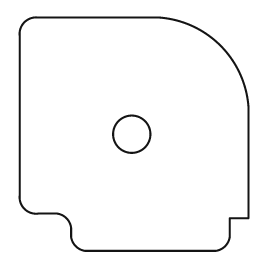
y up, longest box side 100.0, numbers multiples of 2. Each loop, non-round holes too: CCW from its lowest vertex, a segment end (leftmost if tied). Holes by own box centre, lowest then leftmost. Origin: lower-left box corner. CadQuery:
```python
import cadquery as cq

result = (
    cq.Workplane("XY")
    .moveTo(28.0, 0.0)
    .lineTo(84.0, 0.0)
    .threePointArc((88.0, 2.0), (90.0, 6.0))
    .lineTo(90.0, 14.0)
    .lineTo(98.0, 14.0)
    .lineTo(98.0, 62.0)
    .threePointArc((86.0, 88.0), (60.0, 100.0))
    .lineTo(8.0, 100.0)
    .threePointArc((2.0, 98.0), (0.0, 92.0))
    .lineTo(0.0, 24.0)
    .threePointArc((2.0, 18.0), (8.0, 16.0))
    .lineTo(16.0, 16.0)
    .threePointArc((20.0, 14.0), (22.0, 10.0))
    .lineTo(22.0, 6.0)
    .threePointArc((24.0, 2.0), (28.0, 0.0))
    .close()
    .moveTo(48.0, 50.0)
    .circle(8.0)
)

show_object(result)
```